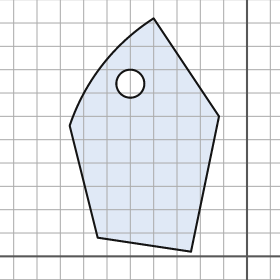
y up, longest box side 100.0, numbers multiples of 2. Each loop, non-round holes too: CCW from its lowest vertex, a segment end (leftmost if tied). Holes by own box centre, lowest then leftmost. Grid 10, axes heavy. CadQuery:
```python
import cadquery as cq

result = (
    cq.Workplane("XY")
    .moveTo(-24.0, 2.0)
    .lineTo(-12.0, 60.0)
    .lineTo(-40.0, 102.0)
    .threePointArc((-62.0, 82.0), (-76.0, 56.0))
    .lineTo(-64.0, 8.0)
    .close()
    .moveTo(-50.0, 74.0)
    .circle(6.0)
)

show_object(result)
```